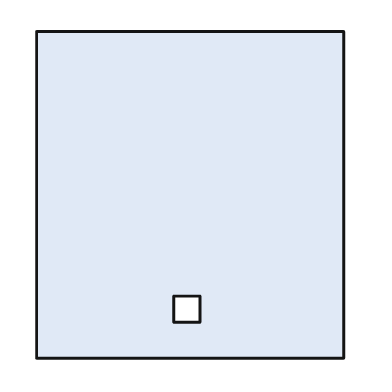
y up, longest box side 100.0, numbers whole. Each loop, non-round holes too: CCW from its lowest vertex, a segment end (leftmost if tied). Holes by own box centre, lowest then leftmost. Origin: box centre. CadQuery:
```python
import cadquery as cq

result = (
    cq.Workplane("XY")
    .moveTo(-47.0, -50.0)
    .lineTo(47.0, -50.0)
    .lineTo(47.0, 50.0)
    .lineTo(-47.0, 50.0)
    .close()
    .moveTo(-5.0, -39.0)
    .lineTo(3.0, -39.0)
    .lineTo(3.0, -31.0)
    .lineTo(-5.0, -31.0)
    .close()
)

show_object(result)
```